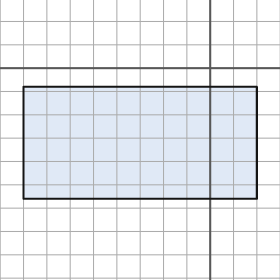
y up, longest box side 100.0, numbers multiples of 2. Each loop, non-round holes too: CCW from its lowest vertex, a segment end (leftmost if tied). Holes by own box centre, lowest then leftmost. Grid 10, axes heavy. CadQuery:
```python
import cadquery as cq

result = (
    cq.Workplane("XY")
    .moveTo(-80.0, -56.0)
    .lineTo(20.0, -56.0)
    .lineTo(20.0, -8.0)
    .lineTo(-80.0, -8.0)
    .close()
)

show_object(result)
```